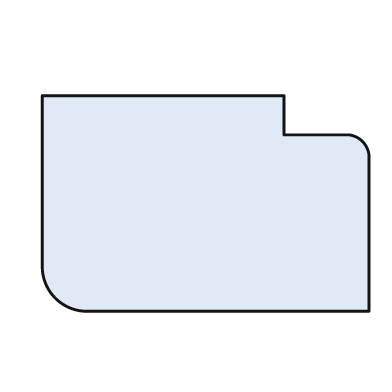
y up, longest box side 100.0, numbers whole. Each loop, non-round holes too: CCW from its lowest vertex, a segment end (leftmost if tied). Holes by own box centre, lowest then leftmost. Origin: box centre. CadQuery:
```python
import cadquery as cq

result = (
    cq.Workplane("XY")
    .moveTo(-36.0, -33.0)
    .lineTo(50.0, -33.0)
    .lineTo(50.0, 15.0)
    .threePointArc((48.0, 19.0), (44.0, 21.0))
    .lineTo(24.0, 21.0)
    .lineTo(24.0, 33.0)
    .lineTo(-50.0, 33.0)
    .lineTo(-50.0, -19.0)
    .threePointArc((-46.0, -29.0), (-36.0, -33.0))
    .close()
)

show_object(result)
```